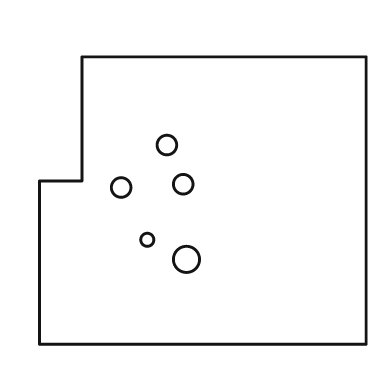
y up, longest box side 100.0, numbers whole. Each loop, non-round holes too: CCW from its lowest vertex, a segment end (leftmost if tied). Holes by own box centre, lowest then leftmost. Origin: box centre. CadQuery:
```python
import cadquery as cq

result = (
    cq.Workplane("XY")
    .moveTo(-50.0, -44.0)
    .lineTo(50.0, -44.0)
    .lineTo(50.0, 44.0)
    .lineTo(-37.0, 44.0)
    .lineTo(-37.0, 6.0)
    .lineTo(-50.0, 6.0)
    .close()
    .moveTo(-5.0, -18.0)
    .circle(4.0)
    .moveTo(-17.0, -12.0)
    .circle(2.0)
    .moveTo(-25.0, 4.0)
    .circle(3.0)
    .moveTo(-6.0, 5.0)
    .circle(3.0)
    .moveTo(-11.0, 17.0)
    .circle(3.0)
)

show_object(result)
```